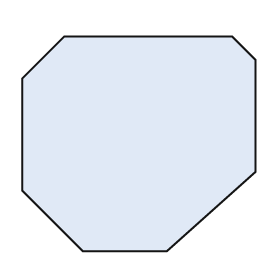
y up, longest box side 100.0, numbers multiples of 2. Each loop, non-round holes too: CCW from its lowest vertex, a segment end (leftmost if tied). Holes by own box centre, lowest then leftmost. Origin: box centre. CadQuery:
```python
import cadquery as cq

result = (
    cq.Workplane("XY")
    .moveTo(-24.0, -46.0)
    .lineTo(12.0, -46.0)
    .lineTo(50.0, -12.0)
    .lineTo(50.0, 36.0)
    .lineTo(40.0, 46.0)
    .lineTo(-32.0, 46.0)
    .lineTo(-50.0, 28.0)
    .lineTo(-50.0, -20.0)
    .close()
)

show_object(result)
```